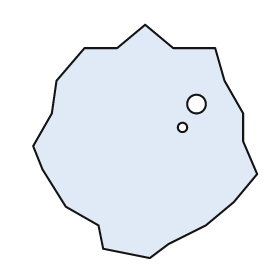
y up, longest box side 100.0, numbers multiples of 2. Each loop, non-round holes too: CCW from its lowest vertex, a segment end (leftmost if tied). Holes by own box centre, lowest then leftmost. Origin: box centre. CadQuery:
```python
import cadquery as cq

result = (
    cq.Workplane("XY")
    .moveTo(2.0, -50.0)
    .lineTo(10.0, -44.0)
    .lineTo(26.0, -36.0)
    .lineTo(38.0, -26.0)
    .lineTo(48.0, -14.0)
    .lineTo(42.0, 0.0)
    .lineTo(42.0, 12.0)
    .lineTo(34.0, 26.0)
    .lineTo(30.0, 40.0)
    .lineTo(12.0, 40.0)
    .lineTo(0.0, 50.0)
    .lineTo(-12.0, 40.0)
    .lineTo(-26.0, 40.0)
    .lineTo(-38.0, 26.0)
    .lineTo(-40.0, 12.0)
    .lineTo(-48.0, -2.0)
    .lineTo(-44.0, -12.0)
    .lineTo(-34.0, -28.0)
    .lineTo(-20.0, -36.0)
    .lineTo(-18.0, -46.0)
    .close()
    .moveTo(16.0, 6.0)
    .circle(2.0)
    .moveTo(22.0, 16.0)
    .circle(4.0)
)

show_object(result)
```